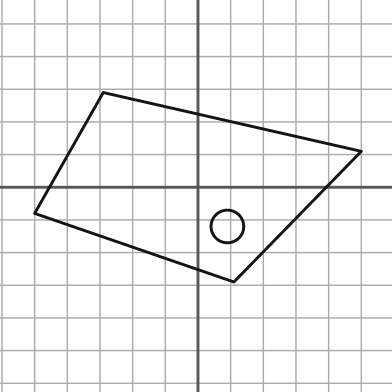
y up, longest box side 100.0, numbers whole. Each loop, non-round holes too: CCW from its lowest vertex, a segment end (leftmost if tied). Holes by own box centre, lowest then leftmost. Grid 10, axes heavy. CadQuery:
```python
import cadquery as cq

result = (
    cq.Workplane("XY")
    .moveTo(11.0, -29.0)
    .lineTo(50.0, 11.0)
    .lineTo(-29.0, 29.0)
    .lineTo(-50.0, -8.0)
    .close()
    .moveTo(9.0, -12.0)
    .circle(5.0)
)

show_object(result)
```